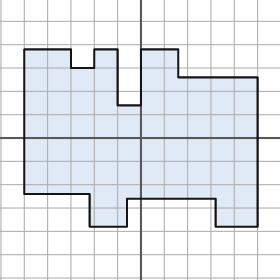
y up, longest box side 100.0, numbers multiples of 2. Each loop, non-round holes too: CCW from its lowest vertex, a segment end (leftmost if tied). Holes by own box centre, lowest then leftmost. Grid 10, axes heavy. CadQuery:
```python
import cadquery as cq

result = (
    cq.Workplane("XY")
    .moveTo(-22.0, -38.0)
    .lineTo(-6.0, -38.0)
    .lineTo(-6.0, -26.0)
    .lineTo(32.0, -26.0)
    .lineTo(32.0, -38.0)
    .lineTo(50.0, -38.0)
    .lineTo(50.0, 26.0)
    .lineTo(16.0, 26.0)
    .lineTo(16.0, 38.0)
    .lineTo(0.0, 38.0)
    .lineTo(0.0, 14.0)
    .lineTo(-10.0, 14.0)
    .lineTo(-10.0, 38.0)
    .lineTo(-20.0, 38.0)
    .lineTo(-20.0, 30.0)
    .lineTo(-30.0, 30.0)
    .lineTo(-30.0, 38.0)
    .lineTo(-50.0, 38.0)
    .lineTo(-50.0, -24.0)
    .lineTo(-22.0, -24.0)
    .close()
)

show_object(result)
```